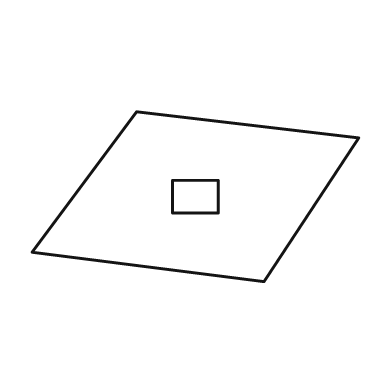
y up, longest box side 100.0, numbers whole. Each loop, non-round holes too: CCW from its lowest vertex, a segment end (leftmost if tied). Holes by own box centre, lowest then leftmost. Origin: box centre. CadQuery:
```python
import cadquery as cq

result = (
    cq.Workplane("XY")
    .moveTo(21.0, -26.0)
    .lineTo(50.0, 18.0)
    .lineTo(-18.0, 26.0)
    .lineTo(-50.0, -17.0)
    .close()
    .moveTo(-7.0, -5.0)
    .lineTo(7.0, -5.0)
    .lineTo(7.0, 5.0)
    .lineTo(-7.0, 5.0)
    .close()
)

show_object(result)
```